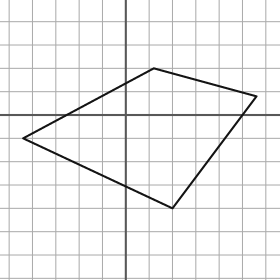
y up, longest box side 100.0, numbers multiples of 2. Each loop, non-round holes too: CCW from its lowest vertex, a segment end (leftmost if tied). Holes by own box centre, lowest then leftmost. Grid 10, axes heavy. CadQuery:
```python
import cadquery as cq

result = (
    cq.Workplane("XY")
    .moveTo(20.0, -40.0)
    .lineTo(56.0, 8.0)
    .lineTo(12.0, 20.0)
    .lineTo(-44.0, -10.0)
    .close()
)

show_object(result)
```